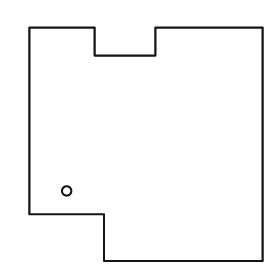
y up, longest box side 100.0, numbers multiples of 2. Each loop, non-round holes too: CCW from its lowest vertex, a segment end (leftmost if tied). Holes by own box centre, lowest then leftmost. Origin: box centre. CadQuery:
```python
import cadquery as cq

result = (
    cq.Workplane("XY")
    .moveTo(-18.0, -50.0)
    .lineTo(50.0, -50.0)
    .lineTo(50.0, 50.0)
    .lineTo(4.0, 50.0)
    .lineTo(4.0, 38.0)
    .lineTo(-22.0, 38.0)
    .lineTo(-22.0, 50.0)
    .lineTo(-50.0, 50.0)
    .lineTo(-50.0, -30.0)
    .lineTo(-18.0, -30.0)
    .close()
    .moveTo(-34.0, -20.0)
    .circle(2.0)
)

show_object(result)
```